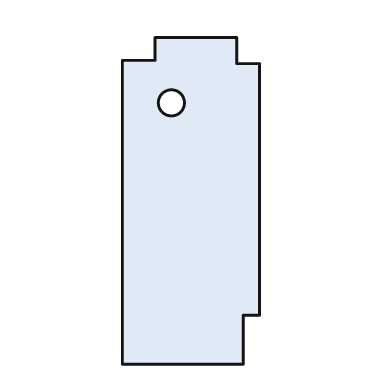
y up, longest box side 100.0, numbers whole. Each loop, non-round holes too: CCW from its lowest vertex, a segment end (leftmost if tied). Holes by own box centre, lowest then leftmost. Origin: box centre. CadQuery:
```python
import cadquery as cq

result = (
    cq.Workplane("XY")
    .moveTo(-21.0, -50.0)
    .lineTo(16.0, -50.0)
    .lineTo(16.0, -35.0)
    .lineTo(21.0, -35.0)
    .lineTo(21.0, 42.0)
    .lineTo(14.0, 42.0)
    .lineTo(14.0, 50.0)
    .lineTo(-11.0, 50.0)
    .lineTo(-11.0, 43.0)
    .lineTo(-21.0, 43.0)
    .close()
    .moveTo(-6.0, 30.0)
    .circle(4.0)
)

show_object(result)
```